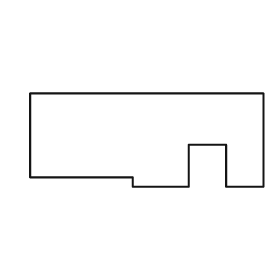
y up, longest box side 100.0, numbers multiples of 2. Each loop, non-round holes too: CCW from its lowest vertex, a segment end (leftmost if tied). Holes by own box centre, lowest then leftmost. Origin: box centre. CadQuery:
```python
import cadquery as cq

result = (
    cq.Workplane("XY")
    .moveTo(-6.0, -20.0)
    .lineTo(18.0, -20.0)
    .lineTo(18.0, -2.0)
    .lineTo(34.0, -2.0)
    .lineTo(34.0, -20.0)
    .lineTo(50.0, -20.0)
    .lineTo(50.0, 20.0)
    .lineTo(-50.0, 20.0)
    .lineTo(-50.0, -16.0)
    .lineTo(-6.0, -16.0)
    .close()
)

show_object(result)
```